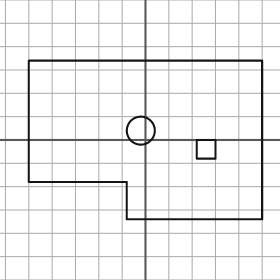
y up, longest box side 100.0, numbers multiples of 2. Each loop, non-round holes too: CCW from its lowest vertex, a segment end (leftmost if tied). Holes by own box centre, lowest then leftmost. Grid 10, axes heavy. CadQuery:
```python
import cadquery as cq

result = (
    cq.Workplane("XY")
    .moveTo(-8.0, -34.0)
    .lineTo(50.0, -34.0)
    .lineTo(50.0, 34.0)
    .lineTo(-50.0, 34.0)
    .lineTo(-50.0, -18.0)
    .lineTo(-8.0, -18.0)
    .close()
    .moveTo(22.0, -8.0)
    .lineTo(30.0, -8.0)
    .lineTo(30.0, 0.0)
    .lineTo(22.0, 0.0)
    .close()
    .moveTo(-2.0, 4.0)
    .circle(6.0)
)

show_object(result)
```